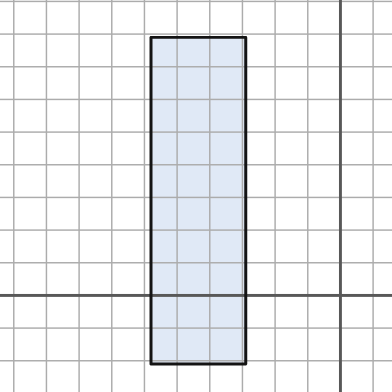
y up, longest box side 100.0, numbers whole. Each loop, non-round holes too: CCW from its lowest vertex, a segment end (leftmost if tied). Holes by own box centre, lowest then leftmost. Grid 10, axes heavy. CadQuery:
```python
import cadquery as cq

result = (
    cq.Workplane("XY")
    .moveTo(-58.0, -21.0)
    .lineTo(-29.0, -21.0)
    .lineTo(-29.0, 79.0)
    .lineTo(-58.0, 79.0)
    .close()
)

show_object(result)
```